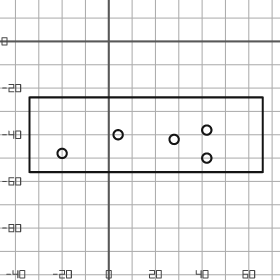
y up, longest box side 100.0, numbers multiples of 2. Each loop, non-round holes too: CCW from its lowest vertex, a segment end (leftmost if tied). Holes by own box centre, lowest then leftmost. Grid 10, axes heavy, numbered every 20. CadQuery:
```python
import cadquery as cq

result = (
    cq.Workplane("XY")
    .moveTo(-34.0, -56.0)
    .lineTo(66.0, -56.0)
    .lineTo(66.0, -24.0)
    .lineTo(-34.0, -24.0)
    .close()
    .moveTo(42.0, -50.0)
    .circle(2.0)
    .moveTo(-20.0, -48.0)
    .circle(2.0)
    .moveTo(28.0, -42.0)
    .circle(2.0)
    .moveTo(4.0, -40.0)
    .circle(2.0)
    .moveTo(42.0, -38.0)
    .circle(2.0)
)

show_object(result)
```